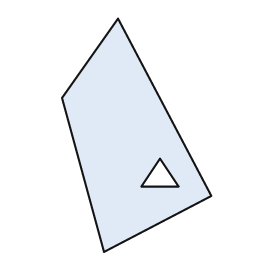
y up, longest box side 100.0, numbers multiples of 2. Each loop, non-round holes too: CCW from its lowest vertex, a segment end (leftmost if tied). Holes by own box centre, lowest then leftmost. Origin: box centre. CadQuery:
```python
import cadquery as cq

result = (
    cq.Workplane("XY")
    .moveTo(-14.0, -50.0)
    .lineTo(32.0, -26.0)
    .lineTo(-8.0, 50.0)
    .lineTo(-32.0, 16.0)
    .close()
    .moveTo(2.0, -22.0)
    .lineTo(18.0, -22.0)
    .lineTo(10.0, -10.0)
    .close()
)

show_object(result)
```